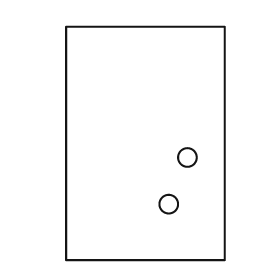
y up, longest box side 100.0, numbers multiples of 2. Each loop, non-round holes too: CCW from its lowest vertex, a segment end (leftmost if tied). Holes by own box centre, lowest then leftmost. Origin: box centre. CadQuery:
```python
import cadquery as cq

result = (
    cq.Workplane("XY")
    .moveTo(-34.0, -50.0)
    .lineTo(34.0, -50.0)
    .lineTo(34.0, 50.0)
    .lineTo(-34.0, 50.0)
    .close()
    .moveTo(10.0, -26.0)
    .circle(4.0)
    .moveTo(18.0, -6.0)
    .circle(4.0)
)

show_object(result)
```